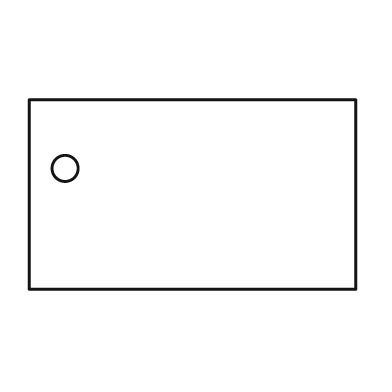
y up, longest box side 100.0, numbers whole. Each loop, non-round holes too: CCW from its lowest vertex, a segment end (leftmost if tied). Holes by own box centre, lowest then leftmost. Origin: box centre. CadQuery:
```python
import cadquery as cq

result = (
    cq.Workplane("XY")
    .moveTo(-50.0, -29.0)
    .lineTo(50.0, -29.0)
    .lineTo(50.0, 29.0)
    .lineTo(-50.0, 29.0)
    .close()
    .moveTo(-39.0, 8.0)
    .circle(4.0)
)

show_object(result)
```